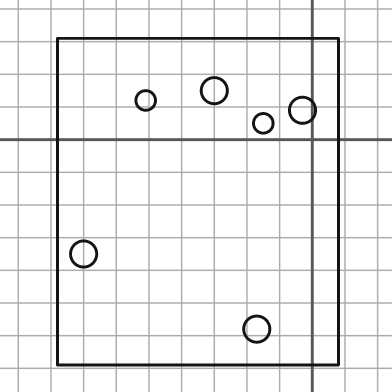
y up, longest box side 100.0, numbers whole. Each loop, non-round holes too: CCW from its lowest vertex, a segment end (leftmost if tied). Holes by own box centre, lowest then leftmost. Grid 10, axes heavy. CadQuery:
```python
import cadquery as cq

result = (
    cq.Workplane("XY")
    .moveTo(-78.0, -69.0)
    .lineTo(8.0, -69.0)
    .lineTo(8.0, 31.0)
    .lineTo(-78.0, 31.0)
    .close()
    .moveTo(-17.0, -58.0)
    .circle(4.0)
    .moveTo(-70.0, -35.0)
    .circle(4.0)
    .moveTo(-15.0, 5.0)
    .circle(3.0)
    .moveTo(-3.0, 9.0)
    .circle(4.0)
    .moveTo(-51.0, 12.0)
    .circle(3.0)
    .moveTo(-30.0, 15.0)
    .circle(4.0)
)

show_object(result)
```